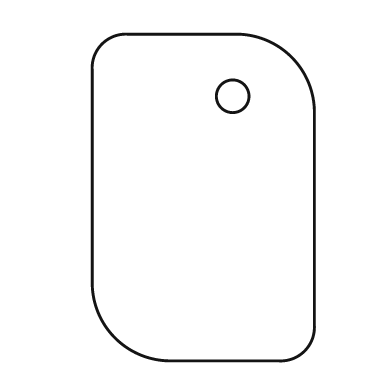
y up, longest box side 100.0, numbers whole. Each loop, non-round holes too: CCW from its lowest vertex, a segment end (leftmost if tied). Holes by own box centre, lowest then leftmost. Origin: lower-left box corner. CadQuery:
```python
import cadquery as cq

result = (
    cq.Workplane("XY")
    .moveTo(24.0, 0.0)
    .lineTo(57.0, 0.0)
    .threePointArc((65.0, 3.0), (68.0, 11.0))
    .lineTo(68.0, 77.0)
    .threePointArc((61.0, 93.0), (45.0, 100.0))
    .lineTo(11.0, 100.0)
    .threePointArc((3.0, 97.0), (0.0, 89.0))
    .lineTo(0.0, 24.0)
    .threePointArc((7.0, 7.0), (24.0, 0.0))
    .close()
    .moveTo(43.0, 81.0)
    .circle(5.0)
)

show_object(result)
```